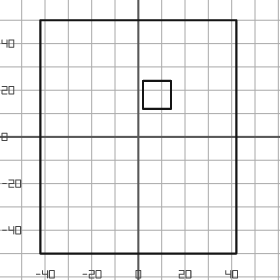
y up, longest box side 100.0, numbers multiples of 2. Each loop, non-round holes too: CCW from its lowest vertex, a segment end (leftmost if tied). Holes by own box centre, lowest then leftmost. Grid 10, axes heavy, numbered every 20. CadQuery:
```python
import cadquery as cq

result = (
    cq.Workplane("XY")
    .moveTo(-42.0, -50.0)
    .lineTo(42.0, -50.0)
    .lineTo(42.0, 50.0)
    .lineTo(-42.0, 50.0)
    .close()
    .moveTo(2.0, 12.0)
    .lineTo(14.0, 12.0)
    .lineTo(14.0, 24.0)
    .lineTo(2.0, 24.0)
    .close()
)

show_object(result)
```